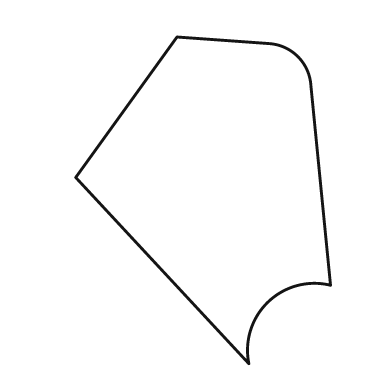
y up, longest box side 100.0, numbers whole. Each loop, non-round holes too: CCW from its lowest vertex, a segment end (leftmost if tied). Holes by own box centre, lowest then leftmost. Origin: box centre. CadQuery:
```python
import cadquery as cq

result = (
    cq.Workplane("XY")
    .moveTo(14.0, -50.0)
    .threePointArc((20.0, -31.0), (39.0, -26.0))
    .lineTo(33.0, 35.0)
    .threePointArc((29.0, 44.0), (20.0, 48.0))
    .lineTo(-8.0, 50.0)
    .lineTo(-39.0, 7.0)
    .close()
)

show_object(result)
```